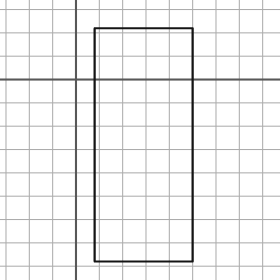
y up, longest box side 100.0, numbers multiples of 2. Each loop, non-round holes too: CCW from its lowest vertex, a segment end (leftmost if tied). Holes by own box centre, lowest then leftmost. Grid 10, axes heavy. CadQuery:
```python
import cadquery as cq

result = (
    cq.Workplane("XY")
    .moveTo(8.0, -78.0)
    .lineTo(50.0, -78.0)
    .lineTo(50.0, 22.0)
    .lineTo(8.0, 22.0)
    .close()
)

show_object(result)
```